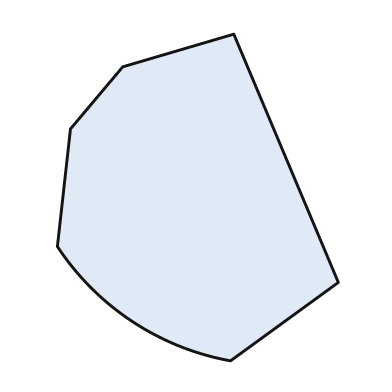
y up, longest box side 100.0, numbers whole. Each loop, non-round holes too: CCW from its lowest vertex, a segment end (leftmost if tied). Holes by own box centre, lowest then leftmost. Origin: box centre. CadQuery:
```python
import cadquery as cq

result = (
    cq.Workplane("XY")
    .moveTo(10.0, -50.0)
    .lineTo(43.0, -26.0)
    .lineTo(11.0, 50.0)
    .lineTo(-23.0, 40.0)
    .lineTo(-39.0, 21.0)
    .lineTo(-43.0, -15.0)
    .threePointArc((-20.0, -38.0), (10.0, -50.0))
    .close()
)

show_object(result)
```